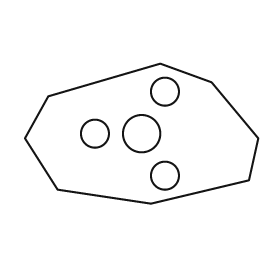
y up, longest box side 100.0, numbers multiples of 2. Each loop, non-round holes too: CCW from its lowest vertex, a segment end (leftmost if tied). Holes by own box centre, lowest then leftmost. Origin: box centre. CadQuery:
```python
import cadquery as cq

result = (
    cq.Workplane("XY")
    .moveTo(4.0, -30.0)
    .lineTo(46.0, -20.0)
    .lineTo(50.0, -2.0)
    .lineTo(30.0, 22.0)
    .lineTo(8.0, 30.0)
    .lineTo(-40.0, 16.0)
    .lineTo(-50.0, -2.0)
    .lineTo(-36.0, -24.0)
    .close()
    .moveTo(10.0, -18.0)
    .circle(6.0)
    .moveTo(-20.0, 0.0)
    .circle(6.0)
    .moveTo(0.0, 0.0)
    .circle(8.0)
    .moveTo(10.0, 18.0)
    .circle(6.0)
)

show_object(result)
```